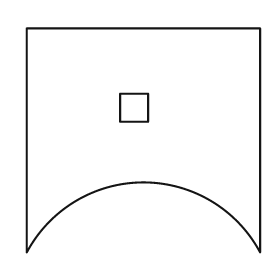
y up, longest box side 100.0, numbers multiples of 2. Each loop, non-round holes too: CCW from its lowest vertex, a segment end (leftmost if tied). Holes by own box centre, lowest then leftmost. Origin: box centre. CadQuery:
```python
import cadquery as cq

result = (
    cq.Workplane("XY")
    .moveTo(-50.0, -48.0)
    .threePointArc((0.0, -18.0), (50.0, -48.0))
    .lineTo(50.0, 48.0)
    .lineTo(-50.0, 48.0)
    .close()
    .moveTo(-10.0, 8.0)
    .lineTo(2.0, 8.0)
    .lineTo(2.0, 20.0)
    .lineTo(-10.0, 20.0)
    .close()
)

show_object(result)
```